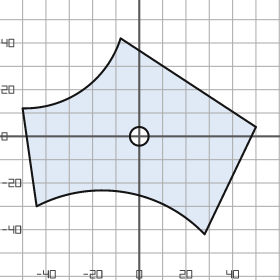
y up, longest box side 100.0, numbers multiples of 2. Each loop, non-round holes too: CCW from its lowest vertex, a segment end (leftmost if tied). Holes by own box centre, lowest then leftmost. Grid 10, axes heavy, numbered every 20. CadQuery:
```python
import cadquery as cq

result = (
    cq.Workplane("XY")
    .moveTo(28.0, -42.0)
    .lineTo(50.0, 4.0)
    .lineTo(-8.0, 42.0)
    .threePointArc((-24.0, 20.0), (-50.0, 12.0))
    .lineTo(-44.0, -30.0)
    .threePointArc((-6.0, -24.0), (28.0, -42.0))
    .close()
    .moveTo(0.0, 0.0)
    .circle(4.0)
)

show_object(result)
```